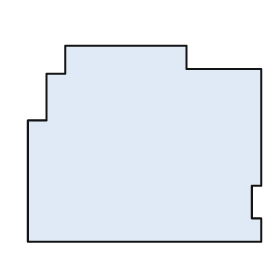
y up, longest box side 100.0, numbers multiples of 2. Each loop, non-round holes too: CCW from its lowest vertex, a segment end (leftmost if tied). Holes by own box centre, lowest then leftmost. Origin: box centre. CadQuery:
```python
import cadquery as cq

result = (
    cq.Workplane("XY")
    .moveTo(-50.0, -42.0)
    .lineTo(50.0, -42.0)
    .lineTo(50.0, -32.0)
    .lineTo(46.0, -32.0)
    .lineTo(46.0, -18.0)
    .lineTo(50.0, -18.0)
    .lineTo(50.0, 32.0)
    .lineTo(18.0, 32.0)
    .lineTo(18.0, 42.0)
    .lineTo(-34.0, 42.0)
    .lineTo(-34.0, 30.0)
    .lineTo(-42.0, 30.0)
    .lineTo(-42.0, 10.0)
    .lineTo(-50.0, 10.0)
    .close()
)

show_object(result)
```